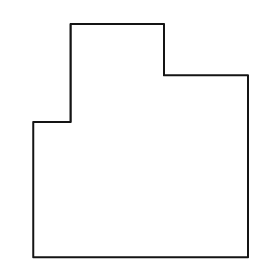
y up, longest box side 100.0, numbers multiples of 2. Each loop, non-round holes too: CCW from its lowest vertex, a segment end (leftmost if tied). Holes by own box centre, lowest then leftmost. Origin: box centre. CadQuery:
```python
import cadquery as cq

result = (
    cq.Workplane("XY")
    .moveTo(-46.0, -50.0)
    .lineTo(46.0, -50.0)
    .lineTo(46.0, 28.0)
    .lineTo(10.0, 28.0)
    .lineTo(10.0, 50.0)
    .lineTo(-30.0, 50.0)
    .lineTo(-30.0, 8.0)
    .lineTo(-46.0, 8.0)
    .close()
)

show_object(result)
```